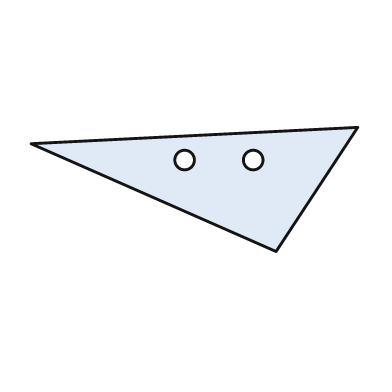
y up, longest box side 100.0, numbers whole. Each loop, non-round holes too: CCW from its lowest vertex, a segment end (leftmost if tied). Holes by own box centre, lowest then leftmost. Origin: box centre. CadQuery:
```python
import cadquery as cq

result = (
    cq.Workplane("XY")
    .moveTo(25.0, -19.0)
    .lineTo(50.0, 19.0)
    .lineTo(-50.0, 14.0)
    .close()
    .moveTo(-3.0, 9.0)
    .circle(3.0)
    .moveTo(18.0, 9.0)
    .circle(3.0)
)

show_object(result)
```